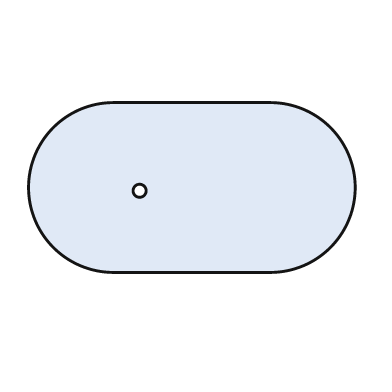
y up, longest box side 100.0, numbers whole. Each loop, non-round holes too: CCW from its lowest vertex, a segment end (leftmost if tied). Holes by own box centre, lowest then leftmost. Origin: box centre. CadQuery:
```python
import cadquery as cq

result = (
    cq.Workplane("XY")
    .moveTo(-24.0, -26.0)
    .lineTo(24.0, -26.0)
    .threePointArc((50.0, 0.0), (24.0, 26.0))
    .lineTo(-24.0, 26.0)
    .threePointArc((-50.0, 0.0), (-24.0, -26.0))
    .close()
    .moveTo(-16.0, -1.0)
    .circle(2.0)
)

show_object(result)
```